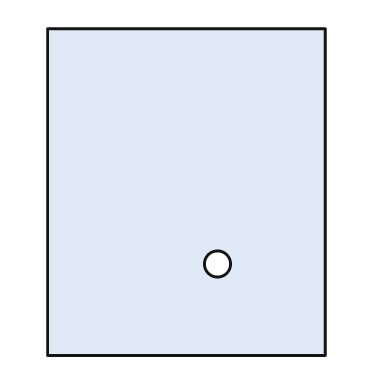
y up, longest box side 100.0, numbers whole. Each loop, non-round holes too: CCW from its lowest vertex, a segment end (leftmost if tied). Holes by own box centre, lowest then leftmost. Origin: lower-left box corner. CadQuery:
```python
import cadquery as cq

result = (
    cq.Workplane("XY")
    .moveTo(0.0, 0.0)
    .lineTo(85.0, 0.0)
    .lineTo(85.0, 100.0)
    .lineTo(0.0, 100.0)
    .close()
    .moveTo(52.0, 28.0)
    .circle(4.0)
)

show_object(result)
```